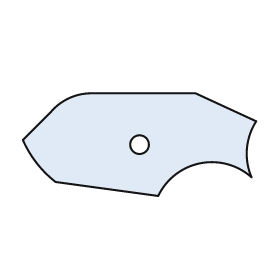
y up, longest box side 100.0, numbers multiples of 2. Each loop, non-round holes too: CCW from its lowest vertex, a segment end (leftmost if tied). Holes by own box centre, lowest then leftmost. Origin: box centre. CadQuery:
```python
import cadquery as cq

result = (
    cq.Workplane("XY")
    .moveTo(8.0, -22.0)
    .threePointArc((26.0, -8.0), (48.0, -14.0))
    .threePointArc((46.0, -2.0), (50.0, 10.0))
    .lineTo(24.0, 22.0)
    .lineTo(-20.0, 22.0)
    .threePointArc((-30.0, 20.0), (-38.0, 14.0))
    .lineTo(-50.0, 2.0)
    .threePointArc((-44.0, -8.0), (-36.0, -16.0))
    .close()
    .moveTo(0.0, 0.0)
    .circle(4.0)
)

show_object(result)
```